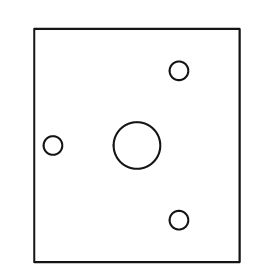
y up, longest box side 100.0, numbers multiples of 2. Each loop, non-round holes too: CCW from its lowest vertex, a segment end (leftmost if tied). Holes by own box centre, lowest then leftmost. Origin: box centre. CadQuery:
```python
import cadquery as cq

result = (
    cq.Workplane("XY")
    .moveTo(-44.0, -50.0)
    .lineTo(44.0, -50.0)
    .lineTo(44.0, 50.0)
    .lineTo(-44.0, 50.0)
    .close()
    .moveTo(18.0, -32.0)
    .circle(4.0)
    .moveTo(-36.0, 0.0)
    .circle(4.0)
    .moveTo(0.0, 0.0)
    .circle(10.0)
    .moveTo(18.0, 32.0)
    .circle(4.0)
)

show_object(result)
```